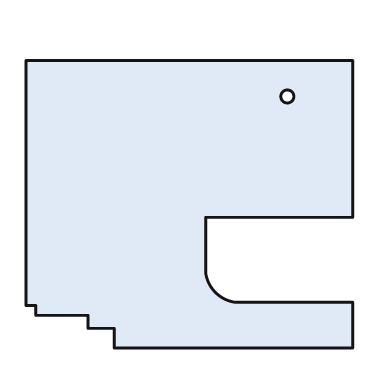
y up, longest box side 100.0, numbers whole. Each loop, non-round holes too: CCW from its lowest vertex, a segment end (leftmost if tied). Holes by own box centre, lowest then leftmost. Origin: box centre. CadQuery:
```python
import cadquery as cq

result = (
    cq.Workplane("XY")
    .moveTo(-23.0, -44.0)
    .lineTo(50.0, -44.0)
    .lineTo(50.0, -30.0)
    .lineTo(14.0, -30.0)
    .threePointArc((8.0, -27.0), (5.0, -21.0))
    .lineTo(5.0, -4.0)
    .lineTo(50.0, -4.0)
    .lineTo(50.0, 44.0)
    .lineTo(-50.0, 44.0)
    .lineTo(-50.0, -31.0)
    .lineTo(-47.0, -31.0)
    .lineTo(-47.0, -34.0)
    .lineTo(-31.0, -34.0)
    .lineTo(-31.0, -38.0)
    .lineTo(-23.0, -38.0)
    .close()
    .moveTo(30.0, 33.0)
    .circle(2.0)
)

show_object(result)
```